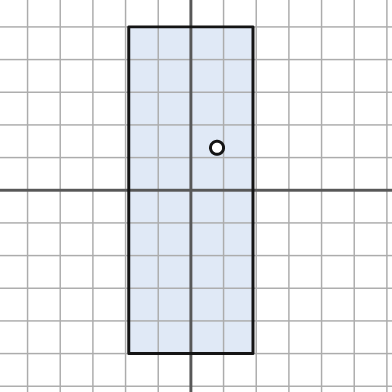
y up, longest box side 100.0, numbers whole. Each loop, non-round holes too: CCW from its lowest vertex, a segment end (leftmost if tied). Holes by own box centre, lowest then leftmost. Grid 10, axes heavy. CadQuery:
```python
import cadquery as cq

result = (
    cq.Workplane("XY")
    .moveTo(-19.0, -50.0)
    .lineTo(19.0, -50.0)
    .lineTo(19.0, 50.0)
    .lineTo(-19.0, 50.0)
    .close()
    .moveTo(8.0, 13.0)
    .circle(2.0)
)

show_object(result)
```